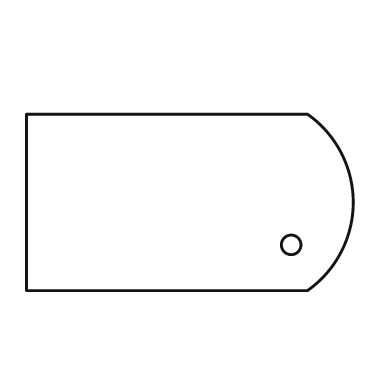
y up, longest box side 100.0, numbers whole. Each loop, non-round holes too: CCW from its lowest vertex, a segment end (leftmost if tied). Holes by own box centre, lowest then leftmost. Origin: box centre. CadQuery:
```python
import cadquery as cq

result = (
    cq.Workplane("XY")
    .moveTo(-50.0, -27.0)
    .lineTo(36.0, -27.0)
    .threePointArc((50.0, 0.0), (36.0, 27.0))
    .lineTo(-50.0, 27.0)
    .close()
    .moveTo(31.0, -13.0)
    .circle(3.0)
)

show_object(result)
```